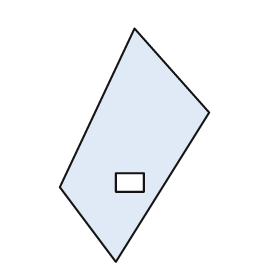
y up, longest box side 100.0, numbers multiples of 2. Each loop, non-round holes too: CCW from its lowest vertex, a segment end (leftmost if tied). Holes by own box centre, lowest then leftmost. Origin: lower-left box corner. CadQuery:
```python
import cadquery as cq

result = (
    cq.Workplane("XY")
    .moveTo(24.0, 0.0)
    .lineTo(64.0, 64.0)
    .lineTo(32.0, 100.0)
    .lineTo(0.0, 32.0)
    .close()
    .moveTo(24.0, 30.0)
    .lineTo(36.0, 30.0)
    .lineTo(36.0, 38.0)
    .lineTo(24.0, 38.0)
    .close()
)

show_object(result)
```